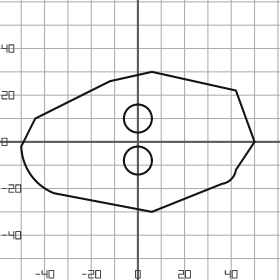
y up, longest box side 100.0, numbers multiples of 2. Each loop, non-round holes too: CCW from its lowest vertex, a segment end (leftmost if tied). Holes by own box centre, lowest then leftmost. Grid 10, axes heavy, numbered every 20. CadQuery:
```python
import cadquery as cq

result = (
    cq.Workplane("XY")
    .moveTo(6.0, -30.0)
    .lineTo(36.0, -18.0)
    .threePointArc((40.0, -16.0), (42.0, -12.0))
    .lineTo(50.0, 0.0)
    .lineTo(42.0, 22.0)
    .lineTo(6.0, 30.0)
    .lineTo(-12.0, 26.0)
    .lineTo(-44.0, 10.0)
    .lineTo(-50.0, -2.0)
    .threePointArc((-46.0, -14.0), (-36.0, -22.0))
    .close()
    .moveTo(0.0, -8.0)
    .circle(6.0)
    .moveTo(0.0, 10.0)
    .circle(6.0)
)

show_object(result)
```